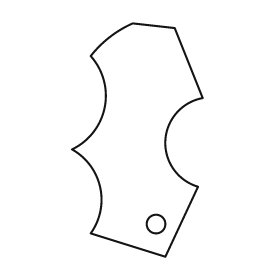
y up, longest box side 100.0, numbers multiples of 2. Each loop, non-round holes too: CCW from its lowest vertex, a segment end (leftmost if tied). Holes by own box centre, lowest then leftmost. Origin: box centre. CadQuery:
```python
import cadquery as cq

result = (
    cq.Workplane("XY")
    .moveTo(12.0, -50.0)
    .lineTo(26.0, -20.0)
    .threePointArc((12.0, 0.0), (28.0, 18.0))
    .lineTo(16.0, 48.0)
    .lineTo(-2.0, 50.0)
    .threePointArc((-12.0, 44.0), (-20.0, 36.0))
    .threePointArc((-14.0, 14.0), (-28.0, -4.0))
    .threePointArc((-16.0, -20.0), (-20.0, -40.0))
    .close()
    .moveTo(8.0, -36.0)
    .circle(4.0)
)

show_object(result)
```